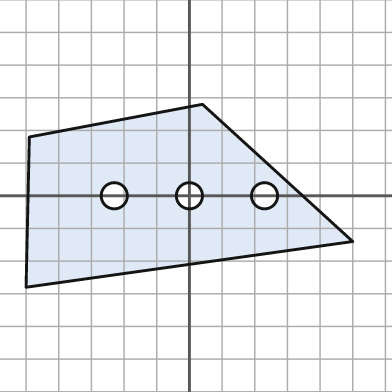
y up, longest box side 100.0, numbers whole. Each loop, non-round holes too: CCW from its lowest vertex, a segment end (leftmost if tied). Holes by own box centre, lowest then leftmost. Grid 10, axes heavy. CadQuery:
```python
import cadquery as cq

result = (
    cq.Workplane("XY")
    .moveTo(-50.0, -28.0)
    .lineTo(50.0, -14.0)
    .lineTo(4.0, 28.0)
    .lineTo(-49.0, 18.0)
    .close()
    .moveTo(-23.0, 0.0)
    .circle(4.0)
    .moveTo(0.0, 0.0)
    .circle(4.0)
    .moveTo(23.0, 0.0)
    .circle(4.0)
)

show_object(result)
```